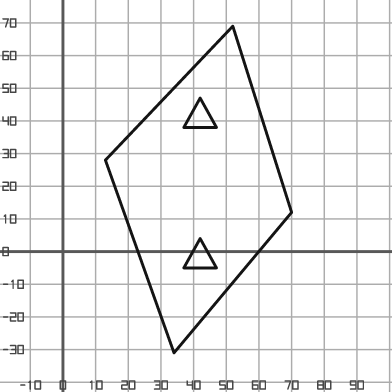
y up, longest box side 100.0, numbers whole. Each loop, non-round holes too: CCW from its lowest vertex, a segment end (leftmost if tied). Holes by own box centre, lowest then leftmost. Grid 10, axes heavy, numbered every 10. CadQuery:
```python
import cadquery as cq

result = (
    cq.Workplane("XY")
    .moveTo(34.0, -31.0)
    .lineTo(70.0, 12.0)
    .lineTo(52.0, 69.0)
    .lineTo(13.0, 28.0)
    .close()
    .moveTo(37.0, -5.0)
    .lineTo(47.0, -5.0)
    .lineTo(42.0, 4.0)
    .close()
    .moveTo(37.0, 38.0)
    .lineTo(47.0, 38.0)
    .lineTo(42.0, 47.0)
    .close()
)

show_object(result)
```